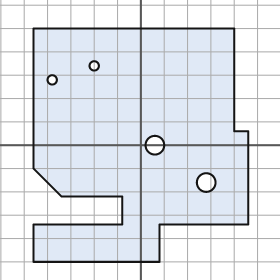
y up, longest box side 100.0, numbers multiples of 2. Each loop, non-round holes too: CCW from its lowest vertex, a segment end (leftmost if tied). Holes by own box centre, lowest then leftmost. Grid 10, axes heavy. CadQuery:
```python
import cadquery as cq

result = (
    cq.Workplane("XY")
    .moveTo(-46.0, -50.0)
    .lineTo(8.0, -50.0)
    .lineTo(8.0, -34.0)
    .lineTo(46.0, -34.0)
    .lineTo(46.0, 6.0)
    .lineTo(40.0, 6.0)
    .lineTo(40.0, 50.0)
    .lineTo(-46.0, 50.0)
    .lineTo(-46.0, -10.0)
    .lineTo(-34.0, -22.0)
    .lineTo(-8.0, -22.0)
    .lineTo(-8.0, -34.0)
    .lineTo(-46.0, -34.0)
    .close()
    .moveTo(28.0, -16.0)
    .circle(4.0)
    .moveTo(6.0, 0.0)
    .circle(4.0)
    .moveTo(-38.0, 28.0)
    .circle(2.0)
    .moveTo(-20.0, 34.0)
    .circle(2.0)
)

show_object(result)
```